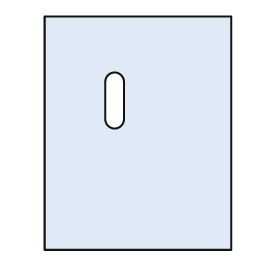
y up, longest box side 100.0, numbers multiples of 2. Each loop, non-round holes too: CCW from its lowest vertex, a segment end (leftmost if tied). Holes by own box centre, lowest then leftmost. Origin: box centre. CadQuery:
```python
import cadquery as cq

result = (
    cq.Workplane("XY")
    .moveTo(-40.0, -50.0)
    .lineTo(40.0, -50.0)
    .lineTo(40.0, 50.0)
    .lineTo(-40.0, 50.0)
    .close()
    .moveTo(-14.0, 6.0)
    .threePointArc((-10.0, 2.0), (-6.0, 6.0))
    .lineTo(-6.0, 22.0)
    .threePointArc((-10.0, 26.0), (-14.0, 22.0))
    .close()
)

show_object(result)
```